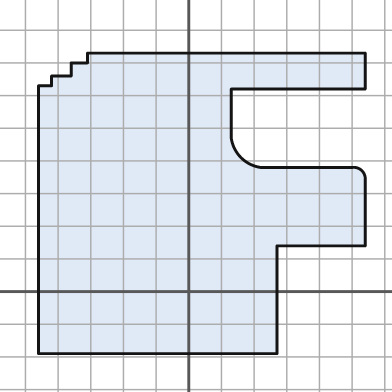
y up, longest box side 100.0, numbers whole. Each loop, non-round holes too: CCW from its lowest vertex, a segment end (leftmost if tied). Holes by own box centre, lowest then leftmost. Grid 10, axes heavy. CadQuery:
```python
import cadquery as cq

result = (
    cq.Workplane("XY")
    .moveTo(-46.0, -19.0)
    .lineTo(27.0, -19.0)
    .lineTo(27.0, 14.0)
    .lineTo(54.0, 14.0)
    .lineTo(54.0, 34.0)
    .threePointArc((53.0, 37.0), (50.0, 38.0))
    .lineTo(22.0, 38.0)
    .threePointArc((16.0, 41.0), (13.0, 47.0))
    .lineTo(13.0, 62.0)
    .lineTo(54.0, 62.0)
    .lineTo(54.0, 73.0)
    .lineTo(-31.0, 73.0)
    .lineTo(-31.0, 70.0)
    .lineTo(-36.0, 70.0)
    .lineTo(-36.0, 66.0)
    .lineTo(-42.0, 66.0)
    .lineTo(-42.0, 63.0)
    .lineTo(-46.0, 63.0)
    .close()
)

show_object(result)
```